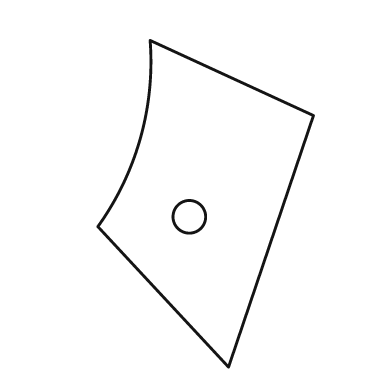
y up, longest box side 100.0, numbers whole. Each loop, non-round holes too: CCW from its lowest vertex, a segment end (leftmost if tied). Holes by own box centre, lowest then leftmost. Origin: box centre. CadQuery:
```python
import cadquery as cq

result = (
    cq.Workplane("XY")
    .moveTo(7.0, -50.0)
    .lineTo(33.0, 27.0)
    .lineTo(-17.0, 50.0)
    .threePointArc((-20.0, 20.0), (-33.0, -7.0))
    .close()
    .moveTo(-5.0, -4.0)
    .circle(5.0)
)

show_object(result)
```